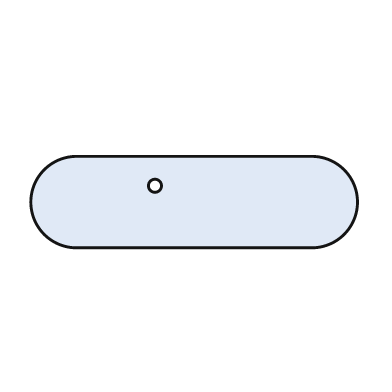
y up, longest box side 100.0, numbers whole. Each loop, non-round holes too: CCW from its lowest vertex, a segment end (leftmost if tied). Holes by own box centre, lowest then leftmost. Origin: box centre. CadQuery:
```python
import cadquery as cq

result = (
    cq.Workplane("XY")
    .moveTo(-36.0, -14.0)
    .lineTo(36.0, -14.0)
    .threePointArc((50.0, 0.0), (36.0, 14.0))
    .lineTo(-36.0, 14.0)
    .threePointArc((-50.0, 0.0), (-36.0, -14.0))
    .close()
    .moveTo(-12.0, 5.0)
    .circle(2.0)
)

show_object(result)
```